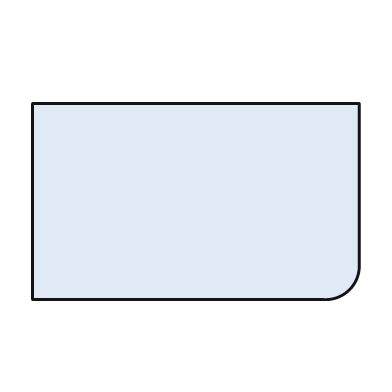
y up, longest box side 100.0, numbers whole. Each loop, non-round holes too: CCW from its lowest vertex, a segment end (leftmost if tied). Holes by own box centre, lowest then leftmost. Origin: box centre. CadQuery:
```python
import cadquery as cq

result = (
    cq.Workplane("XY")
    .moveTo(-50.0, -30.0)
    .lineTo(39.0, -30.0)
    .threePointArc((47.0, -27.0), (50.0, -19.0))
    .lineTo(50.0, 30.0)
    .lineTo(-50.0, 30.0)
    .close()
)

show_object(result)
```